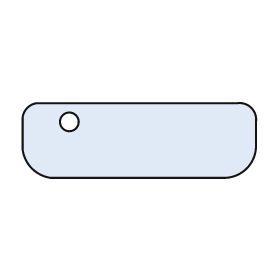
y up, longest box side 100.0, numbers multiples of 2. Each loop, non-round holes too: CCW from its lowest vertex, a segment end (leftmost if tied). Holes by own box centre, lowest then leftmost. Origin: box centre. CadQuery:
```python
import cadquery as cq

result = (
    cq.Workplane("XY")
    .moveTo(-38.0, -16.0)
    .lineTo(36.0, -16.0)
    .threePointArc((46.0, -12.0), (50.0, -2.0))
    .lineTo(50.0, 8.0)
    .threePointArc((48.0, 14.0), (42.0, 16.0))
    .lineTo(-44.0, 16.0)
    .threePointArc((-48.0, 14.0), (-50.0, 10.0))
    .lineTo(-50.0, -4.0)
    .threePointArc((-46.0, -12.0), (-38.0, -16.0))
    .close()
    .moveTo(-30.0, 8.0)
    .circle(4.0)
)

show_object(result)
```